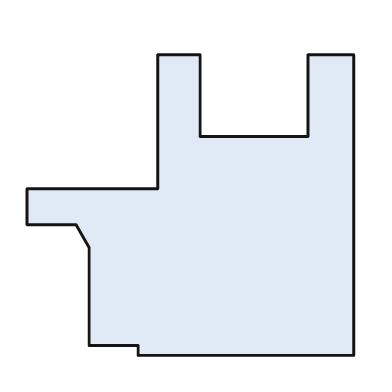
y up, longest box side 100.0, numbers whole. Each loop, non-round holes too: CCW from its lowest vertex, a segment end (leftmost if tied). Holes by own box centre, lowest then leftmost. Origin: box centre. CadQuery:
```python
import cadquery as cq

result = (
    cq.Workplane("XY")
    .moveTo(-16.0, -46.0)
    .lineTo(50.0, -46.0)
    .lineTo(50.0, 46.0)
    .lineTo(36.0, 46.0)
    .lineTo(36.0, 21.0)
    .lineTo(3.0, 21.0)
    .lineTo(3.0, 46.0)
    .lineTo(-10.0, 46.0)
    .lineTo(-10.0, 5.0)
    .lineTo(-50.0, 5.0)
    .lineTo(-50.0, -6.0)
    .lineTo(-35.0, -6.0)
    .lineTo(-31.0, -13.0)
    .lineTo(-31.0, -43.0)
    .lineTo(-16.0, -43.0)
    .close()
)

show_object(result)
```